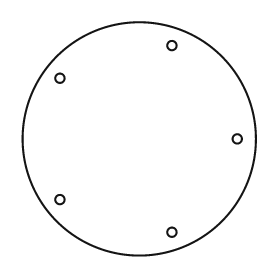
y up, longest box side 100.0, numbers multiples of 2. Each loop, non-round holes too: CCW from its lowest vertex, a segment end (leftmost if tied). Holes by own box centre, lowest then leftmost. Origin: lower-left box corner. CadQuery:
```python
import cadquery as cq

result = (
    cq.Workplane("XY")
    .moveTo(50.0, 50.0)
    .circle(50.0)
    .moveTo(64.0, 10.0)
    .circle(2.0)
    .moveTo(16.0, 24.0)
    .circle(2.0)
    .moveTo(92.0, 50.0)
    .circle(2.0)
    .moveTo(16.0, 76.0)
    .circle(2.0)
    .moveTo(64.0, 90.0)
    .circle(2.0)
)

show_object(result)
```